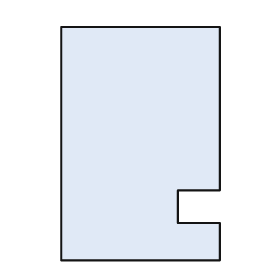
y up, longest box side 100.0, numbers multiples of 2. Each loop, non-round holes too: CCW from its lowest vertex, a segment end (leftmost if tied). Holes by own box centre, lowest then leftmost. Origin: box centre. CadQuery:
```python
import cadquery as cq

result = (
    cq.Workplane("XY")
    .moveTo(-34.0, -50.0)
    .lineTo(34.0, -50.0)
    .lineTo(34.0, -34.0)
    .lineTo(16.0, -34.0)
    .lineTo(16.0, -20.0)
    .lineTo(34.0, -20.0)
    .lineTo(34.0, 50.0)
    .lineTo(-34.0, 50.0)
    .close()
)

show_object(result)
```